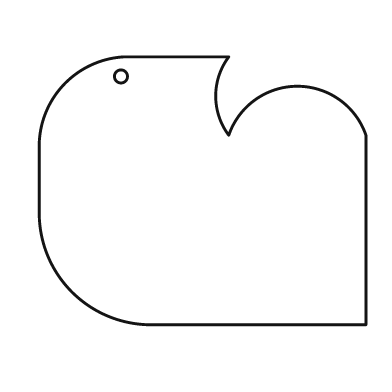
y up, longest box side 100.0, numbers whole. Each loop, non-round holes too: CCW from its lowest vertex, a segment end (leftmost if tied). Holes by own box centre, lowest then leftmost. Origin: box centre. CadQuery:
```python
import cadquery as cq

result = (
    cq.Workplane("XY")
    .moveTo(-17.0, -41.0)
    .lineTo(50.0, -41.0)
    .lineTo(50.0, 17.0)
    .threePointArc((29.0, 32.0), (8.0, 17.0))
    .threePointArc((4.0, 29.0), (8.0, 41.0))
    .lineTo(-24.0, 41.0)
    .threePointArc((-42.0, 33.0), (-50.0, 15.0))
    .lineTo(-50.0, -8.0)
    .threePointArc((-40.0, -31.0), (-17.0, -41.0))
    .close()
    .moveTo(-25.0, 35.0)
    .circle(2.0)
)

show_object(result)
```